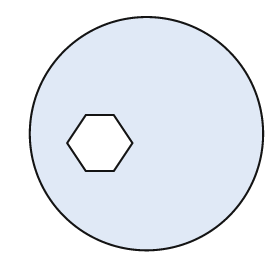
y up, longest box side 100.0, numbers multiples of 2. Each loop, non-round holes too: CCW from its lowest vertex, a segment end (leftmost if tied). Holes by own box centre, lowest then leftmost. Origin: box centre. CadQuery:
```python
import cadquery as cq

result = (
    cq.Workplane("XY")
    .moveTo(0.0, 0.0)
    .circle(50.0)
    .moveTo(-26.0, -16.0)
    .lineTo(-14.0, -16.0)
    .lineTo(-6.0, -4.0)
    .lineTo(-14.0, 8.0)
    .lineTo(-26.0, 8.0)
    .lineTo(-34.0, -4.0)
    .close()
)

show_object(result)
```